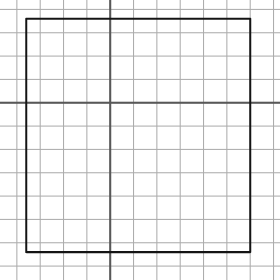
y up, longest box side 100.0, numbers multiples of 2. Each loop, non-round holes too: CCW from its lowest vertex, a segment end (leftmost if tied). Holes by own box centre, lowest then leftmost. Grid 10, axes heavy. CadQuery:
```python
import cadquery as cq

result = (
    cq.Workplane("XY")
    .moveTo(-36.0, -64.0)
    .lineTo(60.0, -64.0)
    .lineTo(60.0, 36.0)
    .lineTo(-36.0, 36.0)
    .close()
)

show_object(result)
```